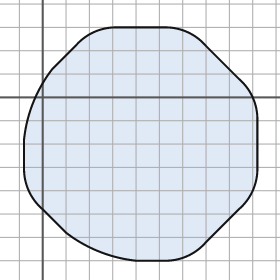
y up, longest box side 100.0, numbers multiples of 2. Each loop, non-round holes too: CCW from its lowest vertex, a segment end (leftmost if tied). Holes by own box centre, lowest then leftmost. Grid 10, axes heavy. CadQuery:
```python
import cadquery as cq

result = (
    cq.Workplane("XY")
    .moveTo(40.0, -70.0)
    .lineTo(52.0, -70.0)
    .threePointArc((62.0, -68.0), (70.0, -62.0))
    .lineTo(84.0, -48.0)
    .threePointArc((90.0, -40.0), (92.0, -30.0))
    .lineTo(92.0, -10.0)
    .threePointArc((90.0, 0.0), (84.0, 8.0))
    .lineTo(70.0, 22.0)
    .threePointArc((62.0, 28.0), (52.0, 30.0))
    .lineTo(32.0, 30.0)
    .threePointArc((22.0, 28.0), (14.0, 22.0))
    .lineTo(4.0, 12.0)
    .threePointArc((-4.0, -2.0), (-8.0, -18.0))
    .lineTo(-8.0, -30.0)
    .threePointArc((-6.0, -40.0), (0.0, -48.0))
    .lineTo(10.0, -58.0)
    .threePointArc((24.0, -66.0), (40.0, -70.0))
    .close()
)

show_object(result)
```